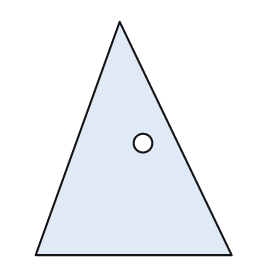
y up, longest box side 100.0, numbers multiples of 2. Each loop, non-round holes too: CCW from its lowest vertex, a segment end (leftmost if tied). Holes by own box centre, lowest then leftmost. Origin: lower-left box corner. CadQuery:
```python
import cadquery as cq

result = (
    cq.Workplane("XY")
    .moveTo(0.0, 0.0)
    .lineTo(84.0, 0.0)
    .lineTo(36.0, 100.0)
    .close()
    .moveTo(46.0, 48.0)
    .circle(4.0)
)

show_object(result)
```